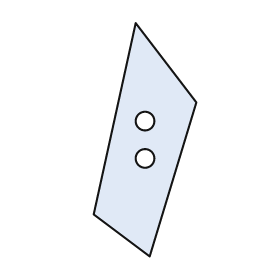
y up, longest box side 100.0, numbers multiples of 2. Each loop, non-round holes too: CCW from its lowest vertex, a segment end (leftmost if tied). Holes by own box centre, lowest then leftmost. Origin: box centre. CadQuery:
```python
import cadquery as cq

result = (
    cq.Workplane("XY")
    .moveTo(2.0, -50.0)
    .lineTo(22.0, 16.0)
    .lineTo(-4.0, 50.0)
    .lineTo(-22.0, -32.0)
    .close()
    .moveTo(0.0, -8.0)
    .circle(4.0)
    .moveTo(0.0, 8.0)
    .circle(4.0)
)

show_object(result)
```